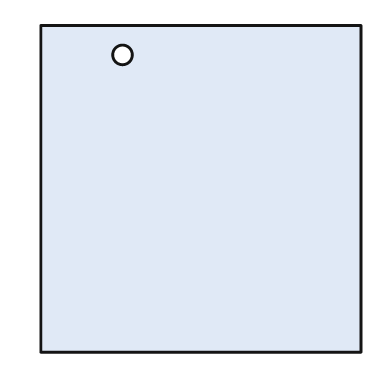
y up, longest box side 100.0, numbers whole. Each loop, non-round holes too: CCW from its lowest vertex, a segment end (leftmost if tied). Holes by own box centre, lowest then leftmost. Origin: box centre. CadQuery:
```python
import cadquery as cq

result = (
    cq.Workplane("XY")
    .moveTo(-49.0, -50.0)
    .lineTo(49.0, -50.0)
    .lineTo(49.0, 50.0)
    .lineTo(-49.0, 50.0)
    .close()
    .moveTo(-24.0, 41.0)
    .circle(3.0)
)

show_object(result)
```